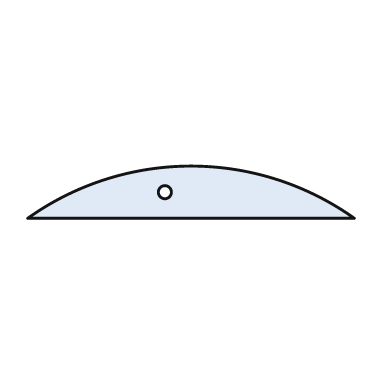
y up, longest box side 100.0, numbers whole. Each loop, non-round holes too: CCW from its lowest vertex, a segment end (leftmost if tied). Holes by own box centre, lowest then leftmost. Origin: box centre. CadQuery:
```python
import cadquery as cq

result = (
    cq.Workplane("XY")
    .moveTo(-50.0, -8.0)
    .lineTo(50.0, -8.0)
    .threePointArc((0.0, 8.0), (-50.0, -8.0))
    .close()
    .moveTo(-8.0, 0.0)
    .circle(2.0)
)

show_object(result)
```